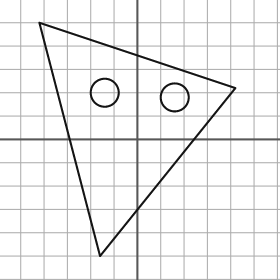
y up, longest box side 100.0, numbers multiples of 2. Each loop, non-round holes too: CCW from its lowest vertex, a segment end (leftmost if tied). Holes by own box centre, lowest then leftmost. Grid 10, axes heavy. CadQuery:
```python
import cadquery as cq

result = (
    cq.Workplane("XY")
    .moveTo(-16.0, -50.0)
    .lineTo(42.0, 22.0)
    .lineTo(-42.0, 50.0)
    .close()
    .moveTo(16.0, 18.0)
    .circle(6.0)
    .moveTo(-14.0, 20.0)
    .circle(6.0)
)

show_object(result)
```